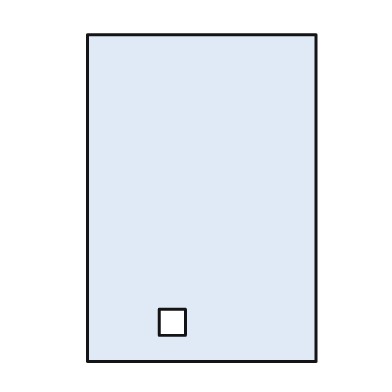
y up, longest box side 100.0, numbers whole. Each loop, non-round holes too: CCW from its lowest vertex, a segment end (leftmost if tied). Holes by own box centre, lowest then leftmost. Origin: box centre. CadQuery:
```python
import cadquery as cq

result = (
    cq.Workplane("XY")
    .moveTo(-35.0, -50.0)
    .lineTo(35.0, -50.0)
    .lineTo(35.0, 50.0)
    .lineTo(-35.0, 50.0)
    .close()
    .moveTo(-13.0, -42.0)
    .lineTo(-5.0, -42.0)
    .lineTo(-5.0, -34.0)
    .lineTo(-13.0, -34.0)
    .close()
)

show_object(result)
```